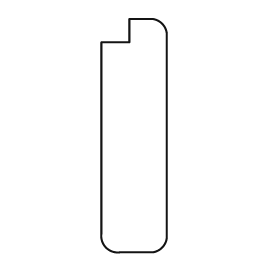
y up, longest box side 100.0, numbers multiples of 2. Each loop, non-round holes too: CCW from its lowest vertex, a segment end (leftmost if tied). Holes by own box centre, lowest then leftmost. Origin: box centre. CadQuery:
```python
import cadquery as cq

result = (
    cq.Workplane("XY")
    .moveTo(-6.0, -50.0)
    .lineTo(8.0, -50.0)
    .threePointArc((12.0, -48.0), (14.0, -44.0))
    .lineTo(14.0, 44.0)
    .threePointArc((12.0, 48.0), (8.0, 50.0))
    .lineTo(-2.0, 50.0)
    .lineTo(-2.0, 40.0)
    .lineTo(-14.0, 40.0)
    .lineTo(-14.0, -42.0)
    .threePointArc((-12.0, -48.0), (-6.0, -50.0))
    .close()
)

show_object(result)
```